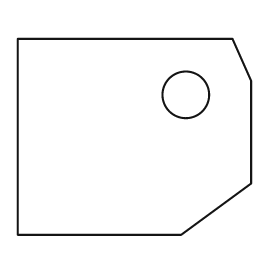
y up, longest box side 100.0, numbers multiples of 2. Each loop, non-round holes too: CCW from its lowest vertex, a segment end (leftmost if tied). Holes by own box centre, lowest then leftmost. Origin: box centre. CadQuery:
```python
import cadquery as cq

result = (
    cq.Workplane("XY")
    .moveTo(-50.0, -42.0)
    .lineTo(20.0, -42.0)
    .lineTo(50.0, -20.0)
    .lineTo(50.0, 24.0)
    .lineTo(42.0, 42.0)
    .lineTo(-50.0, 42.0)
    .close()
    .moveTo(22.0, 18.0)
    .circle(10.0)
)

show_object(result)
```